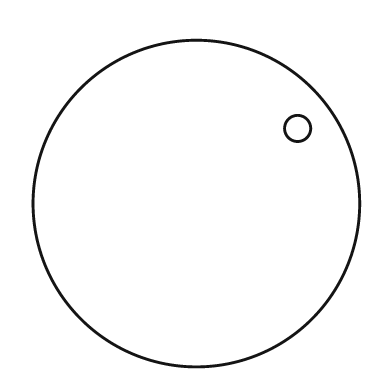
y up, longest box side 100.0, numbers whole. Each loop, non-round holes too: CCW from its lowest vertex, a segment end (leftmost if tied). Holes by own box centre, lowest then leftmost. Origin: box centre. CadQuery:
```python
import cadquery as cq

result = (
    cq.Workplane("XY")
    .moveTo(0.0, 0.0)
    .circle(50.0)
    .moveTo(31.0, 23.0)
    .circle(4.0)
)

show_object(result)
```